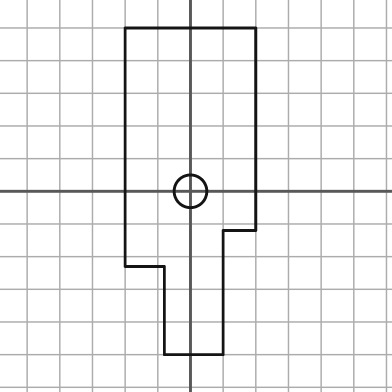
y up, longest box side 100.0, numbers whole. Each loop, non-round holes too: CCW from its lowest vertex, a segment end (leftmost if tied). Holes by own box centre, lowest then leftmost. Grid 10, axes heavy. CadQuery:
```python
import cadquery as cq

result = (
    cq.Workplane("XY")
    .moveTo(-8.0, -50.0)
    .lineTo(10.0, -50.0)
    .lineTo(10.0, -12.0)
    .lineTo(20.0, -12.0)
    .lineTo(20.0, 50.0)
    .lineTo(-20.0, 50.0)
    .lineTo(-20.0, -23.0)
    .lineTo(-8.0, -23.0)
    .close()
    .moveTo(0.0, 0.0)
    .circle(5.0)
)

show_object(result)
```